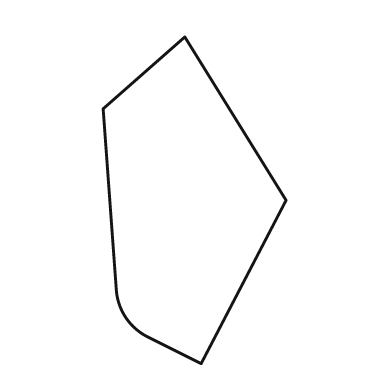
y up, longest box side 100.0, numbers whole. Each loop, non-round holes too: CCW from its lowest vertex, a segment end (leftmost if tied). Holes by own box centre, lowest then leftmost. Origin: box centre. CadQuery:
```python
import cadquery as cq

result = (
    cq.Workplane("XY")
    .moveTo(2.0, -50.0)
    .lineTo(28.0, 0.0)
    .lineTo(-3.0, 50.0)
    .lineTo(-28.0, 28.0)
    .lineTo(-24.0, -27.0)
    .threePointArc((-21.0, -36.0), (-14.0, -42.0))
    .close()
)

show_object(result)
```